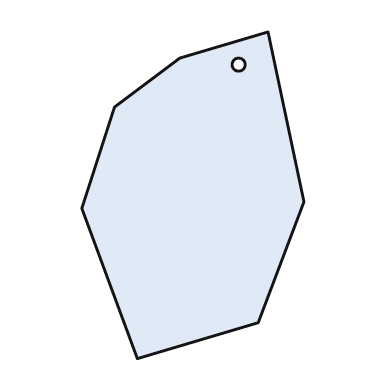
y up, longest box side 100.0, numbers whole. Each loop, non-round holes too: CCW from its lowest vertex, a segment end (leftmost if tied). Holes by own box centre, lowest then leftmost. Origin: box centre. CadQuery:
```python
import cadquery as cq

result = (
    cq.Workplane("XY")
    .moveTo(-17.0, -50.0)
    .lineTo(20.0, -39.0)
    .lineTo(34.0, -2.0)
    .lineTo(23.0, 50.0)
    .lineTo(-4.0, 42.0)
    .lineTo(-24.0, 27.0)
    .lineTo(-34.0, -4.0)
    .close()
    .moveTo(14.0, 40.0)
    .circle(2.0)
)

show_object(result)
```